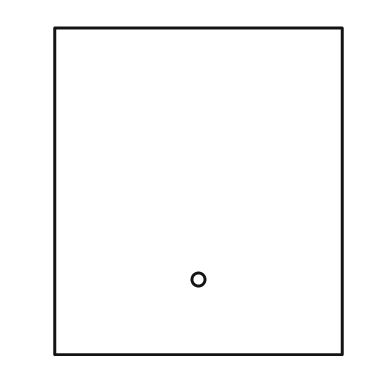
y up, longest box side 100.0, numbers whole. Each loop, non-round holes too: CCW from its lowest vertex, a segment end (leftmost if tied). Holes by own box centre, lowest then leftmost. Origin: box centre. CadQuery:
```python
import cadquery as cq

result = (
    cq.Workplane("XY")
    .moveTo(-44.0, -50.0)
    .lineTo(44.0, -50.0)
    .lineTo(44.0, 50.0)
    .lineTo(-44.0, 50.0)
    .close()
    .moveTo(0.0, -27.0)
    .circle(2.0)
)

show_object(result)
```